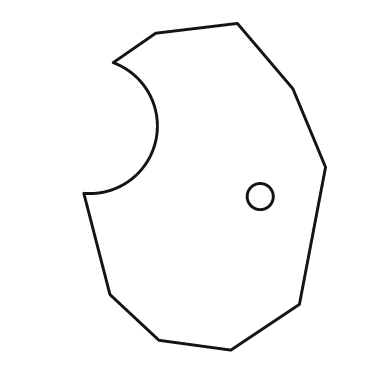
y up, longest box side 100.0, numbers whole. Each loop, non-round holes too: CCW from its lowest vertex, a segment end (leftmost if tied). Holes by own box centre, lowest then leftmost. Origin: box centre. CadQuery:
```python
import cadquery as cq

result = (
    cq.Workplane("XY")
    .moveTo(8.0, -50.0)
    .lineTo(29.0, -36.0)
    .lineTo(37.0, 6.0)
    .lineTo(27.0, 30.0)
    .lineTo(10.0, 50.0)
    .lineTo(-15.0, 47.0)
    .lineTo(-28.0, 38.0)
    .threePointArc((-15.0, 14.0), (-37.0, -2.0))
    .lineTo(-29.0, -33.0)
    .lineTo(-14.0, -47.0)
    .close()
    .moveTo(17.0, -3.0)
    .circle(4.0)
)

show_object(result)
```